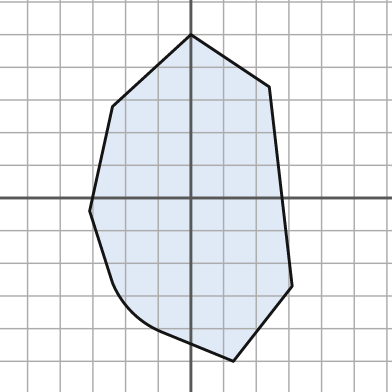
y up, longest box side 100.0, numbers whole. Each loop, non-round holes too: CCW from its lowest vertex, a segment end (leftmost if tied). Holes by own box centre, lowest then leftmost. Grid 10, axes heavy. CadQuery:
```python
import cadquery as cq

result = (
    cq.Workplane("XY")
    .moveTo(13.0, -50.0)
    .lineTo(31.0, -27.0)
    .lineTo(24.0, 34.0)
    .lineTo(0.0, 50.0)
    .lineTo(-24.0, 28.0)
    .lineTo(-31.0, -4.0)
    .lineTo(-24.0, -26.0)
    .threePointArc((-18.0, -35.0), (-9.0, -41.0))
    .close()
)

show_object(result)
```